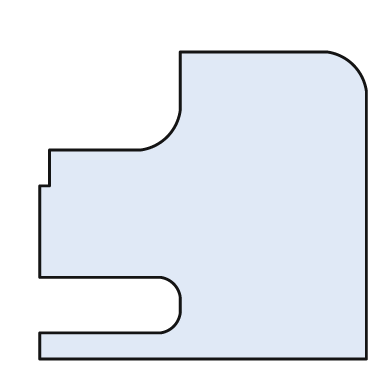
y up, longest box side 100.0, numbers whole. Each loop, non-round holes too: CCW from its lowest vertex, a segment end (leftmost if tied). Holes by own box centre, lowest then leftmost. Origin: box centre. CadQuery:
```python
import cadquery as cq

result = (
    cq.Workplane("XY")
    .moveTo(-50.0, -47.0)
    .lineTo(50.0, -47.0)
    .lineTo(50.0, 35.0)
    .threePointArc((46.0, 43.0), (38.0, 47.0))
    .lineTo(-7.0, 47.0)
    .lineTo(-7.0, 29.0)
    .threePointArc((-11.0, 21.0), (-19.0, 17.0))
    .lineTo(-47.0, 17.0)
    .lineTo(-47.0, 6.0)
    .lineTo(-50.0, 6.0)
    .lineTo(-50.0, -22.0)
    .lineTo(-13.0, -22.0)
    .threePointArc((-9.0, -24.0), (-7.0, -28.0))
    .lineTo(-7.0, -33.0)
    .threePointArc((-9.0, -37.0), (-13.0, -39.0))
    .lineTo(-50.0, -39.0)
    .close()
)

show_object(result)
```